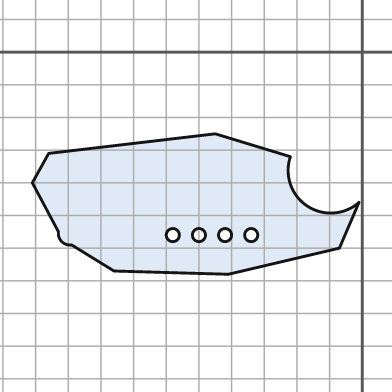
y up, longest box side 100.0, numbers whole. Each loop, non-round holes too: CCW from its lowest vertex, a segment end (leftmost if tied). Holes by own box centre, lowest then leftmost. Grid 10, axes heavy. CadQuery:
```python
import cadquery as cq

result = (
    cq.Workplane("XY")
    .moveTo(-41.0, -68.0)
    .lineTo(-7.0, -60.0)
    .lineTo(-1.0, -46.0)
    .threePointArc((-17.0, -47.0), (-22.0, -32.0))
    .lineTo(-45.0, -25.0)
    .lineTo(-96.0, -31.0)
    .lineTo(-101.0, -40.0)
    .lineTo(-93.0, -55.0)
    .threePointArc((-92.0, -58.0), (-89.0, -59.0))
    .lineTo(-76.0, -67.0)
    .close()
    .moveTo(-58.0, -56.0)
    .circle(2.0)
    .moveTo(-50.0, -56.0)
    .circle(2.0)
    .moveTo(-42.0, -56.0)
    .circle(2.0)
    .moveTo(-34.0, -56.0)
    .circle(2.0)
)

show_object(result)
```